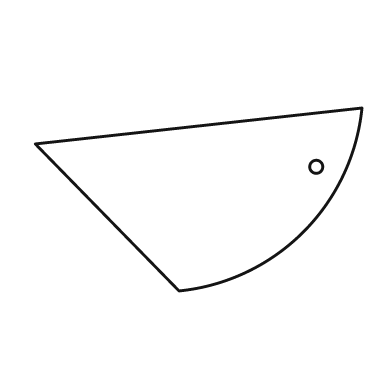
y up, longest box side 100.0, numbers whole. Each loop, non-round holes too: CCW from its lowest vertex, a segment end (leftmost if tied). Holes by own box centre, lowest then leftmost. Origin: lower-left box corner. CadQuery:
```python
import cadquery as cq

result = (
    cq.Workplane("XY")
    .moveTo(44.0, 0.0)
    .threePointArc((82.0, 18.0), (100.0, 56.0))
    .lineTo(0.0, 45.0)
    .close()
    .moveTo(86.0, 38.0)
    .circle(2.0)
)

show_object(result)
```